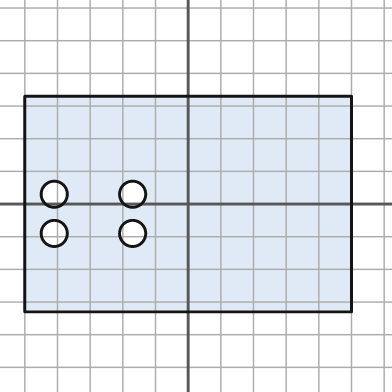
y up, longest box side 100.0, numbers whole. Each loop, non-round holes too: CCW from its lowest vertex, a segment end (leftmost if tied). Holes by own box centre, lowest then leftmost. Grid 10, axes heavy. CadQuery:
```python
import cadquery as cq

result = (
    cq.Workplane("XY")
    .moveTo(-50.0, -33.0)
    .lineTo(50.0, -33.0)
    .lineTo(50.0, 33.0)
    .lineTo(-50.0, 33.0)
    .close()
    .moveTo(-41.0, -9.0)
    .circle(4.0)
    .moveTo(-17.0, -9.0)
    .circle(4.0)
    .moveTo(-41.0, 3.0)
    .circle(4.0)
    .moveTo(-17.0, 3.0)
    .circle(4.0)
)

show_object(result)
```